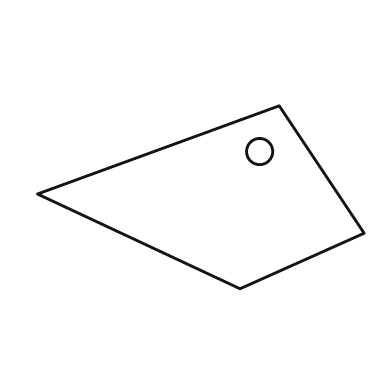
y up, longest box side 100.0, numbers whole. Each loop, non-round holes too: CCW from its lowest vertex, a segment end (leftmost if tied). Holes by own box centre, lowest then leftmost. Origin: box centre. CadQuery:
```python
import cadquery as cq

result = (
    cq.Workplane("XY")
    .moveTo(12.0, -28.0)
    .lineTo(50.0, -11.0)
    .lineTo(24.0, 28.0)
    .lineTo(-50.0, 1.0)
    .close()
    .moveTo(18.0, 14.0)
    .circle(4.0)
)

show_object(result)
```